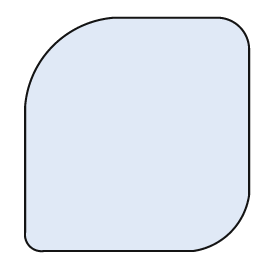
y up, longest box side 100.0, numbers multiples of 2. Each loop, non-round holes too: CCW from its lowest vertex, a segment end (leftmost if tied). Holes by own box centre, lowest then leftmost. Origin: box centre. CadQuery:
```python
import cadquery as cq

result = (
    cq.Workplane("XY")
    .moveTo(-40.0, -50.0)
    .lineTo(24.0, -50.0)
    .threePointArc((40.0, -42.0), (48.0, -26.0))
    .lineTo(48.0, 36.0)
    .threePointArc((44.0, 46.0), (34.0, 50.0))
    .lineTo(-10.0, 50.0)
    .threePointArc((-36.0, 38.0), (-48.0, 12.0))
    .lineTo(-48.0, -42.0)
    .threePointArc((-46.0, -48.0), (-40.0, -50.0))
    .close()
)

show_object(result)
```